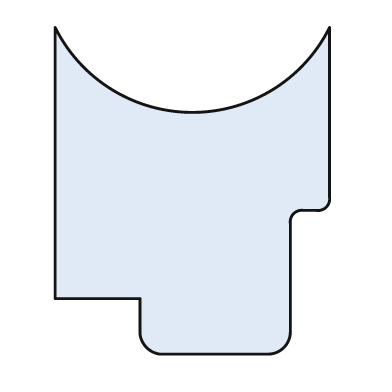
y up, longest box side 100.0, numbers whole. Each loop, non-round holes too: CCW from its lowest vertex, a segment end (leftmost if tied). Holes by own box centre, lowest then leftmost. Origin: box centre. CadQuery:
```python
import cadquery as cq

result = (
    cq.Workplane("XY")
    .moveTo(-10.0, -50.0)
    .lineTo(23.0, -50.0)
    .threePointArc((28.0, -48.0), (30.0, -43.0))
    .lineTo(30.0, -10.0)
    .threePointArc((31.0, -7.0), (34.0, -6.0))
    .lineTo(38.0, -6.0)
    .threePointArc((41.0, -5.0), (42.0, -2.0))
    .lineTo(42.0, 50.0)
    .threePointArc((0.0, 24.0), (-42.0, 50.0))
    .lineTo(-42.0, -33.0)
    .lineTo(-16.0, -33.0)
    .lineTo(-16.0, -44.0)
    .threePointArc((-14.0, -48.0), (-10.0, -50.0))
    .close()
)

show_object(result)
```